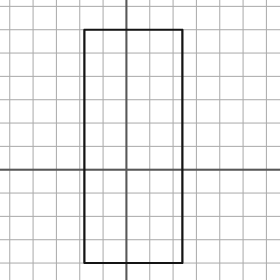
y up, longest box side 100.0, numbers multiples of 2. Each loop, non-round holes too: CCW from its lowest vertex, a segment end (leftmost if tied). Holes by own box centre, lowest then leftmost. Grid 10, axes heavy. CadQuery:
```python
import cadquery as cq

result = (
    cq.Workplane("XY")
    .moveTo(-18.0, -40.0)
    .lineTo(24.0, -40.0)
    .lineTo(24.0, 60.0)
    .lineTo(-18.0, 60.0)
    .close()
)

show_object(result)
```